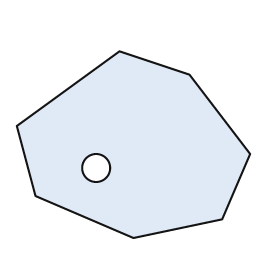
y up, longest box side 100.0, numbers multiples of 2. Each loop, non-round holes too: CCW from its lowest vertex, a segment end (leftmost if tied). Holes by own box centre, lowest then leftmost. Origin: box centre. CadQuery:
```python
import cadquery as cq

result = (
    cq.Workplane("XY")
    .moveTo(0.0, -40.0)
    .lineTo(38.0, -32.0)
    .lineTo(50.0, -4.0)
    .lineTo(24.0, 30.0)
    .lineTo(-6.0, 40.0)
    .lineTo(-50.0, 8.0)
    .lineTo(-42.0, -22.0)
    .close()
    .moveTo(-16.0, -10.0)
    .circle(6.0)
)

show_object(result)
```